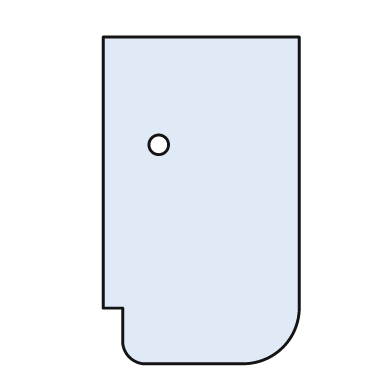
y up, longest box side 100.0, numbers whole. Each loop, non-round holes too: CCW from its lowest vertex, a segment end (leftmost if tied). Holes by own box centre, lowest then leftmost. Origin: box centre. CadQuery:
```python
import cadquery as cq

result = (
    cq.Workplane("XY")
    .moveTo(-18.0, -50.0)
    .lineTo(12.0, -50.0)
    .threePointArc((25.0, -45.0), (30.0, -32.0))
    .lineTo(30.0, 50.0)
    .lineTo(-30.0, 50.0)
    .lineTo(-30.0, -33.0)
    .lineTo(-24.0, -33.0)
    .lineTo(-24.0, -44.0)
    .threePointArc((-22.0, -48.0), (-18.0, -50.0))
    .close()
    .moveTo(-13.0, 17.0)
    .circle(3.0)
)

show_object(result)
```